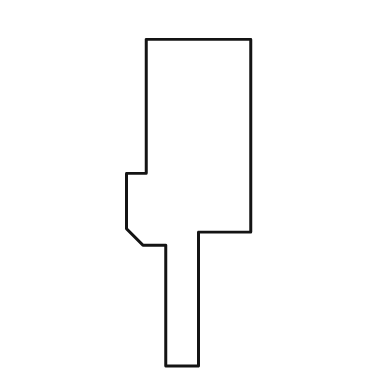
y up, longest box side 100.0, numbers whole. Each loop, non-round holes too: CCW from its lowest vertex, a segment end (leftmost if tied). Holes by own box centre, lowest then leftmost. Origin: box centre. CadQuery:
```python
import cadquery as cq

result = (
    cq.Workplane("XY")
    .moveTo(-7.0, -50.0)
    .lineTo(3.0, -50.0)
    .lineTo(3.0, -9.0)
    .lineTo(19.0, -9.0)
    .lineTo(19.0, 50.0)
    .lineTo(-13.0, 50.0)
    .lineTo(-13.0, 9.0)
    .lineTo(-19.0, 9.0)
    .lineTo(-19.0, -8.0)
    .lineTo(-14.0, -13.0)
    .lineTo(-7.0, -13.0)
    .close()
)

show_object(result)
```